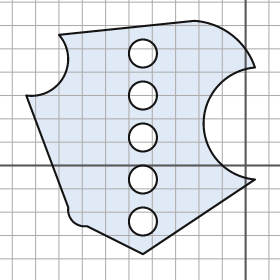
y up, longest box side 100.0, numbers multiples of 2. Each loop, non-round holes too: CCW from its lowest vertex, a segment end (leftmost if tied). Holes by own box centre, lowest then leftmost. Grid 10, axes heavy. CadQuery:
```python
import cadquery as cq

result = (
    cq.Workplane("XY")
    .moveTo(-44.0, -38.0)
    .lineTo(4.0, -6.0)
    .threePointArc((-18.0, 18.0), (4.0, 42.0))
    .threePointArc((-6.0, 56.0), (-22.0, 62.0))
    .lineTo(-80.0, 56.0)
    .threePointArc((-78.0, 38.0), (-94.0, 30.0))
    .lineTo(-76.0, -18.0)
    .threePointArc((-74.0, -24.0), (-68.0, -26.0))
    .close()
    .moveTo(-44.0, -24.0)
    .circle(6.0)
    .moveTo(-44.0, -6.0)
    .circle(6.0)
    .moveTo(-44.0, 12.0)
    .circle(6.0)
    .moveTo(-44.0, 30.0)
    .circle(6.0)
    .moveTo(-44.0, 48.0)
    .circle(6.0)
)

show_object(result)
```